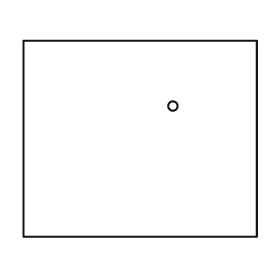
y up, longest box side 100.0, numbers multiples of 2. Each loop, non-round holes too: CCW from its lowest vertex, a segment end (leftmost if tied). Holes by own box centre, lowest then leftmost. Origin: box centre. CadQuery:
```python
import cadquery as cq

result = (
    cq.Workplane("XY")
    .moveTo(-50.0, -42.0)
    .lineTo(50.0, -42.0)
    .lineTo(50.0, 42.0)
    .lineTo(-50.0, 42.0)
    .close()
    .moveTo(14.0, 14.0)
    .circle(2.0)
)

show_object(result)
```